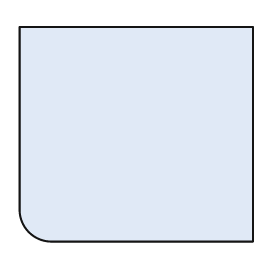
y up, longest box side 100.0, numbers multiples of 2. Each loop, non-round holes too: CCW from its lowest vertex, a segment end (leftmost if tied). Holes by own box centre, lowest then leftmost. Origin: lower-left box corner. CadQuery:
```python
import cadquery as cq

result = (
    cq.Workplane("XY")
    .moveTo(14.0, 0.0)
    .lineTo(100.0, 0.0)
    .lineTo(100.0, 92.0)
    .lineTo(0.0, 92.0)
    .lineTo(0.0, 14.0)
    .threePointArc((4.0, 4.0), (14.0, 0.0))
    .close()
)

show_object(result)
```